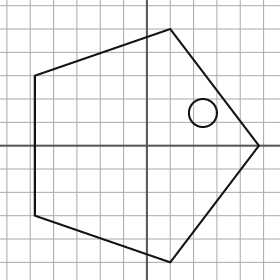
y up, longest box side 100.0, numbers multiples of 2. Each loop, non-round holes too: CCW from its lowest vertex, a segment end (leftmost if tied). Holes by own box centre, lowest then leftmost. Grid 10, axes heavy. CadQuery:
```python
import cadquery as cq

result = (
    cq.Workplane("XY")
    .moveTo(10.0, -50.0)
    .lineTo(48.0, 0.0)
    .lineTo(10.0, 50.0)
    .lineTo(-48.0, 30.0)
    .lineTo(-48.0, -30.0)
    .close()
    .moveTo(24.0, 14.0)
    .circle(6.0)
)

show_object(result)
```